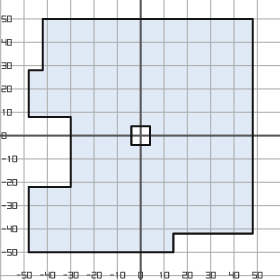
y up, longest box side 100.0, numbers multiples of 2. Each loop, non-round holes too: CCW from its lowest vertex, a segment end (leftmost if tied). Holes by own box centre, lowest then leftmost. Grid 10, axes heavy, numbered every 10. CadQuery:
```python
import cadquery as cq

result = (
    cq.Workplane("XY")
    .moveTo(-48.0, -50.0)
    .lineTo(14.0, -50.0)
    .lineTo(14.0, -42.0)
    .lineTo(48.0, -42.0)
    .lineTo(48.0, 50.0)
    .lineTo(-42.0, 50.0)
    .lineTo(-42.0, 28.0)
    .lineTo(-48.0, 28.0)
    .lineTo(-48.0, 8.0)
    .lineTo(-30.0, 8.0)
    .lineTo(-30.0, -22.0)
    .lineTo(-48.0, -22.0)
    .close()
    .moveTo(-4.0, -4.0)
    .lineTo(4.0, -4.0)
    .lineTo(4.0, 4.0)
    .lineTo(-4.0, 4.0)
    .close()
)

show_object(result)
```